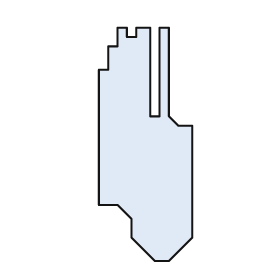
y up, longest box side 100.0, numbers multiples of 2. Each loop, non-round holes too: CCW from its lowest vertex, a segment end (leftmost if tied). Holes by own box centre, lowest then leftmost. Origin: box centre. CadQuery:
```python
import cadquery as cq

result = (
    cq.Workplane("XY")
    .moveTo(4.0, -50.0)
    .lineTo(10.0, -50.0)
    .lineTo(20.0, -40.0)
    .lineTo(20.0, 8.0)
    .lineTo(14.0, 8.0)
    .lineTo(10.0, 12.0)
    .lineTo(10.0, 50.0)
    .lineTo(6.0, 50.0)
    .lineTo(6.0, 12.0)
    .lineTo(2.0, 12.0)
    .lineTo(2.0, 50.0)
    .lineTo(-4.0, 50.0)
    .lineTo(-4.0, 46.0)
    .lineTo(-8.0, 46.0)
    .lineTo(-8.0, 50.0)
    .lineTo(-12.0, 50.0)
    .lineTo(-12.0, 42.0)
    .lineTo(-16.0, 42.0)
    .lineTo(-16.0, 32.0)
    .lineTo(-20.0, 32.0)
    .lineTo(-20.0, -26.0)
    .lineTo(-12.0, -26.0)
    .lineTo(-6.0, -32.0)
    .lineTo(-6.0, -40.0)
    .close()
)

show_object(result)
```